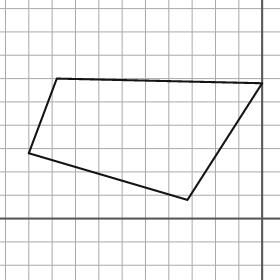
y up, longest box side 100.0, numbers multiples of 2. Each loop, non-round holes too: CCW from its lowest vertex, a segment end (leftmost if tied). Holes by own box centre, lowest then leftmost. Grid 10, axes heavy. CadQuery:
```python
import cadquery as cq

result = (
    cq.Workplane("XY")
    .moveTo(-32.0, 8.0)
    .lineTo(0.0, 58.0)
    .lineTo(-88.0, 60.0)
    .lineTo(-100.0, 28.0)
    .close()
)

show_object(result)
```